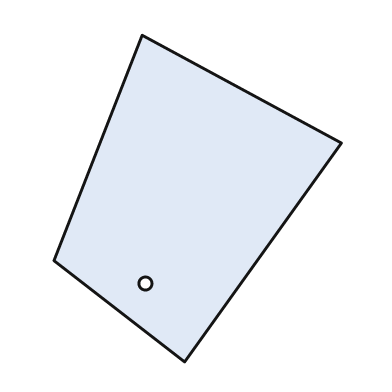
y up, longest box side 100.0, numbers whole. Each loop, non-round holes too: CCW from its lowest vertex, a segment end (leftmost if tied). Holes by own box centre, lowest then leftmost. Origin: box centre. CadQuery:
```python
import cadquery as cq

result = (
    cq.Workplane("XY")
    .moveTo(-4.0, -50.0)
    .lineTo(44.0, 17.0)
    .lineTo(-17.0, 50.0)
    .lineTo(-44.0, -19.0)
    .close()
    .moveTo(-16.0, -26.0)
    .circle(2.0)
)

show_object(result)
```